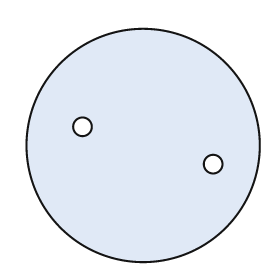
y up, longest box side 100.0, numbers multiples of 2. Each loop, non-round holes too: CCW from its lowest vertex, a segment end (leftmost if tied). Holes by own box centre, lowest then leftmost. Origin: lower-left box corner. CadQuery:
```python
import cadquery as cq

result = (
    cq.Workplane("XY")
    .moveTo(50.0, 50.0)
    .circle(50.0)
    .moveTo(80.0, 42.0)
    .circle(4.0)
    .moveTo(24.0, 58.0)
    .circle(4.0)
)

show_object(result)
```